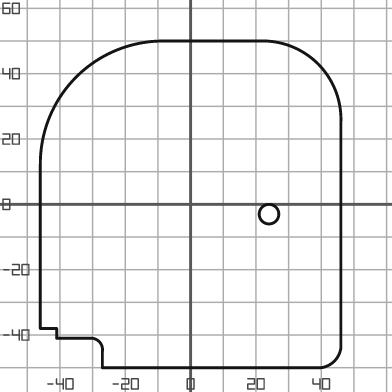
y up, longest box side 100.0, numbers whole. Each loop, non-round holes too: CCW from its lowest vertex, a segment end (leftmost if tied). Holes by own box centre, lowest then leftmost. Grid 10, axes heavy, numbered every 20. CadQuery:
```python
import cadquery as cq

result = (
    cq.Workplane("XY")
    .moveTo(-27.0, -50.0)
    .lineTo(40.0, -50.0)
    .threePointArc((44.0, -48.0), (46.0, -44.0))
    .lineTo(46.0, 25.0)
    .threePointArc((39.0, 43.0), (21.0, 50.0))
    .lineTo(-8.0, 50.0)
    .threePointArc((-35.0, 39.0), (-46.0, 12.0))
    .lineTo(-46.0, -38.0)
    .lineTo(-41.0, -38.0)
    .lineTo(-41.0, -41.0)
    .lineTo(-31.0, -41.0)
    .threePointArc((-28.0, -42.0), (-27.0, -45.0))
    .close()
    .moveTo(24.0, -3.0)
    .circle(3.0)
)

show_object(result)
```